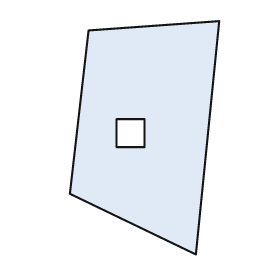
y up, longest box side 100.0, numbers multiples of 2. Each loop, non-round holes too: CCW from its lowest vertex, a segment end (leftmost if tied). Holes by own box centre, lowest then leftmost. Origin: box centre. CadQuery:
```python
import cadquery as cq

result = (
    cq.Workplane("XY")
    .moveTo(22.0, -50.0)
    .lineTo(32.0, 50.0)
    .lineTo(-24.0, 46.0)
    .lineTo(-32.0, -24.0)
    .close()
    .moveTo(-12.0, -4.0)
    .lineTo(0.0, -4.0)
    .lineTo(0.0, 8.0)
    .lineTo(-12.0, 8.0)
    .close()
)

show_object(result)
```